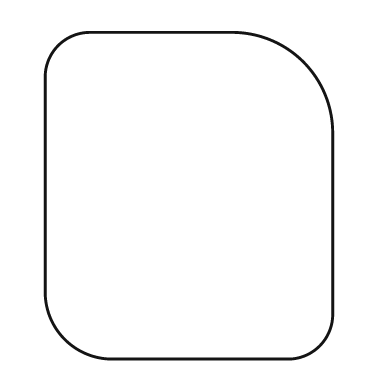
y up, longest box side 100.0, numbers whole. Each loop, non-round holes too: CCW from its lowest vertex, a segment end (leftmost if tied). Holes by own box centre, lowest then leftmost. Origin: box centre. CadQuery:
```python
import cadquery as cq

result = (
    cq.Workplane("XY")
    .moveTo(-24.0, -50.0)
    .lineTo(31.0, -50.0)
    .threePointArc((40.0, -46.0), (44.0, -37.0))
    .lineTo(44.0, 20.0)
    .threePointArc((35.0, 41.0), (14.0, 50.0))
    .lineTo(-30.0, 50.0)
    .threePointArc((-40.0, 46.0), (-44.0, 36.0))
    .lineTo(-44.0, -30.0)
    .threePointArc((-38.0, -44.0), (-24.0, -50.0))
    .close()
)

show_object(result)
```